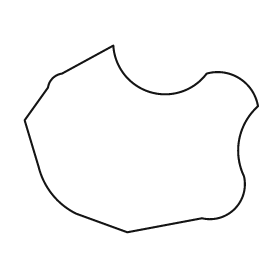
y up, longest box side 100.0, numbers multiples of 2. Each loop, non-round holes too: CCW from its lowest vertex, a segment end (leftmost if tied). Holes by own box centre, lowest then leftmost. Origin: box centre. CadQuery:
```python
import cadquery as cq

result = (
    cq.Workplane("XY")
    .moveTo(-6.0, -40.0)
    .lineTo(26.0, -34.0)
    .threePointArc((40.0, -30.0), (44.0, -16.0))
    .threePointArc((42.0, 0.0), (50.0, 14.0))
    .threePointArc((42.0, 26.0), (28.0, 28.0))
    .threePointArc((4.0, 20.0), (-12.0, 40.0))
    .lineTo(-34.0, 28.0)
    .threePointArc((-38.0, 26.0), (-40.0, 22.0))
    .lineTo(-50.0, 8.0)
    .lineTo(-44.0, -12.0)
    .threePointArc((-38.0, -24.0), (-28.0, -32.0))
    .close()
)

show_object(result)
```